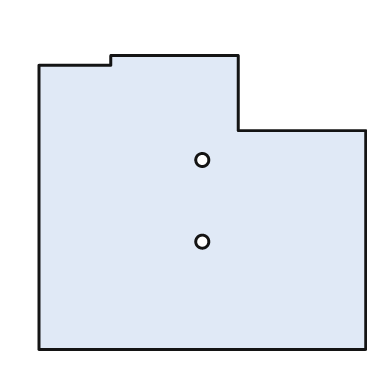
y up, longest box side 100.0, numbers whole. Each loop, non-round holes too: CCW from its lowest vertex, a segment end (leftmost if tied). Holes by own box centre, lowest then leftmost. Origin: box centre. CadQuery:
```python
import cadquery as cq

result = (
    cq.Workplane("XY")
    .moveTo(-50.0, -45.0)
    .lineTo(50.0, -45.0)
    .lineTo(50.0, 22.0)
    .lineTo(11.0, 22.0)
    .lineTo(11.0, 45.0)
    .lineTo(-28.0, 45.0)
    .lineTo(-28.0, 42.0)
    .lineTo(-50.0, 42.0)
    .close()
    .moveTo(0.0, -12.0)
    .circle(2.0)
    .moveTo(0.0, 13.0)
    .circle(2.0)
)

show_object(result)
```